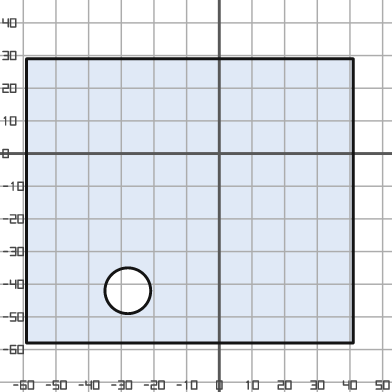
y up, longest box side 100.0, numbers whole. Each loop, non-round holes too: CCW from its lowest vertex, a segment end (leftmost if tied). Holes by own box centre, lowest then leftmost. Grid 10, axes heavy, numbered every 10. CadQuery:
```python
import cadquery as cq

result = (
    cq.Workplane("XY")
    .moveTo(-59.0, -58.0)
    .lineTo(41.0, -58.0)
    .lineTo(41.0, 29.0)
    .lineTo(-59.0, 29.0)
    .close()
    .moveTo(-28.0, -42.0)
    .circle(7.0)
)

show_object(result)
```